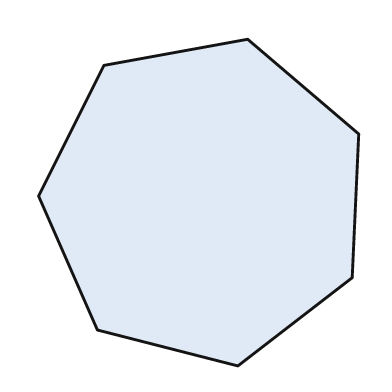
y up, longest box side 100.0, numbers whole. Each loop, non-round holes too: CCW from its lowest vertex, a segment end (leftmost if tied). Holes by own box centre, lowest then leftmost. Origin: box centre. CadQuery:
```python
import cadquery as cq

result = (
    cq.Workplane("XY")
    .moveTo(12.0, -50.0)
    .lineTo(47.0, -23.0)
    .lineTo(49.0, 21.0)
    .lineTo(15.0, 50.0)
    .lineTo(-29.0, 42.0)
    .lineTo(-49.0, 2.0)
    .lineTo(-31.0, -39.0)
    .close()
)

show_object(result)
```